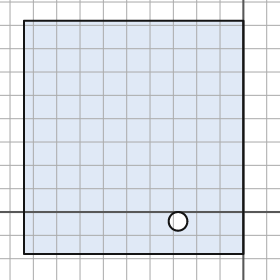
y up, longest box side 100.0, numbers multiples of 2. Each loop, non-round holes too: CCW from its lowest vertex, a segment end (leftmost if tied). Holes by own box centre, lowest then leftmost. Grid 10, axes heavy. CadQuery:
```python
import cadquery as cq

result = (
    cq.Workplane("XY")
    .moveTo(-94.0, -18.0)
    .lineTo(0.0, -18.0)
    .lineTo(0.0, 82.0)
    .lineTo(-94.0, 82.0)
    .close()
    .moveTo(-28.0, -4.0)
    .circle(4.0)
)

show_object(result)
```